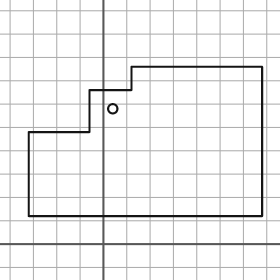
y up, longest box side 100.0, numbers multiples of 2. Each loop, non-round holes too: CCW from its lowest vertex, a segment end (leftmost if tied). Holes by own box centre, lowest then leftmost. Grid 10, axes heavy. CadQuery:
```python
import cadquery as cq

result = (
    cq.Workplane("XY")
    .moveTo(-32.0, 12.0)
    .lineTo(68.0, 12.0)
    .lineTo(68.0, 76.0)
    .lineTo(12.0, 76.0)
    .lineTo(12.0, 66.0)
    .lineTo(-6.0, 66.0)
    .lineTo(-6.0, 48.0)
    .lineTo(-32.0, 48.0)
    .close()
    .moveTo(4.0, 58.0)
    .circle(2.0)
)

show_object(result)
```